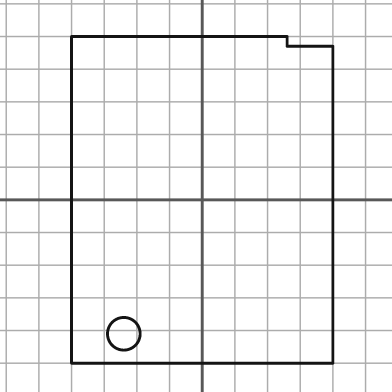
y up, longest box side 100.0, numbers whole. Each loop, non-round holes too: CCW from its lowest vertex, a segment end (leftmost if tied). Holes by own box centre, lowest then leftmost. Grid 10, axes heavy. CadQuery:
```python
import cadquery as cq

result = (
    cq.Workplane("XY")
    .moveTo(-40.0, -50.0)
    .lineTo(40.0, -50.0)
    .lineTo(40.0, 47.0)
    .lineTo(26.0, 47.0)
    .lineTo(26.0, 50.0)
    .lineTo(-40.0, 50.0)
    .close()
    .moveTo(-24.0, -41.0)
    .circle(5.0)
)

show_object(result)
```